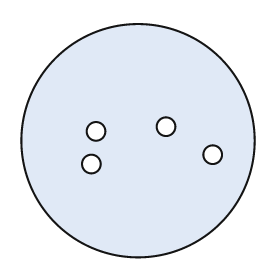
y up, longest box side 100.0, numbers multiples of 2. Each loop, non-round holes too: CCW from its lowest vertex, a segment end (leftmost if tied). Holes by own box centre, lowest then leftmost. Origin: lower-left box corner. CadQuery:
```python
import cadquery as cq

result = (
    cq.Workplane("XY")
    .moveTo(50.0, 50.0)
    .circle(50.0)
    .moveTo(30.0, 40.0)
    .circle(4.0)
    .moveTo(82.0, 44.0)
    .circle(4.0)
    .moveTo(32.0, 54.0)
    .circle(4.0)
    .moveTo(62.0, 56.0)
    .circle(4.0)
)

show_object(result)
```